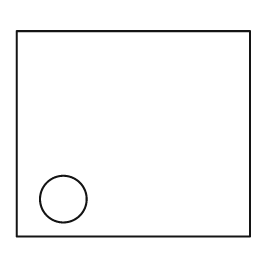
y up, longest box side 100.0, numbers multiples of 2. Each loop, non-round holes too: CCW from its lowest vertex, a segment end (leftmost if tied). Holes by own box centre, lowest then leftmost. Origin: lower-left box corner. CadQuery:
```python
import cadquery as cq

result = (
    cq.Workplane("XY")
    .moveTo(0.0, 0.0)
    .lineTo(100.0, 0.0)
    .lineTo(100.0, 88.0)
    .lineTo(0.0, 88.0)
    .close()
    .moveTo(20.0, 16.0)
    .circle(10.0)
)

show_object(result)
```